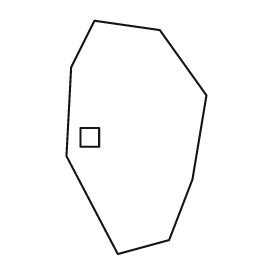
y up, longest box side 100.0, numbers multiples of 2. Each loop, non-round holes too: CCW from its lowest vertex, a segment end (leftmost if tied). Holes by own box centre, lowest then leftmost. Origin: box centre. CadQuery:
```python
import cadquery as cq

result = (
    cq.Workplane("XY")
    .moveTo(-8.0, -50.0)
    .lineTo(14.0, -44.0)
    .lineTo(24.0, -18.0)
    .lineTo(30.0, 18.0)
    .lineTo(10.0, 46.0)
    .lineTo(-18.0, 50.0)
    .lineTo(-28.0, 30.0)
    .lineTo(-30.0, -8.0)
    .close()
    .moveTo(-24.0, -4.0)
    .lineTo(-16.0, -4.0)
    .lineTo(-16.0, 4.0)
    .lineTo(-24.0, 4.0)
    .close()
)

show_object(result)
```